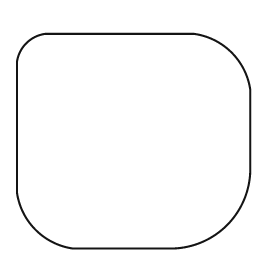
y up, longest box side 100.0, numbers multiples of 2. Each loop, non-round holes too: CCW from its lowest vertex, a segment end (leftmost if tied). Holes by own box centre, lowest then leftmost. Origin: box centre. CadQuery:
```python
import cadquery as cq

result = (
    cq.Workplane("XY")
    .moveTo(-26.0, -46.0)
    .lineTo(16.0, -46.0)
    .threePointArc((40.0, -36.0), (50.0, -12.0))
    .lineTo(50.0, 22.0)
    .threePointArc((42.0, 38.0), (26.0, 46.0))
    .lineTo(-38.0, 46.0)
    .threePointArc((-46.0, 42.0), (-50.0, 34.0))
    .lineTo(-50.0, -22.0)
    .threePointArc((-42.0, -38.0), (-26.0, -46.0))
    .close()
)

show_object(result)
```